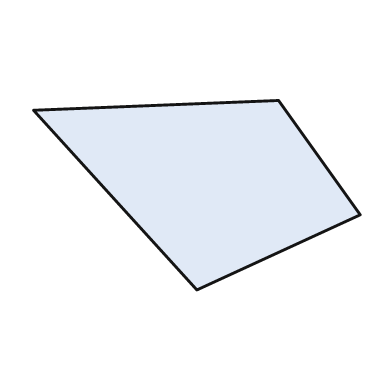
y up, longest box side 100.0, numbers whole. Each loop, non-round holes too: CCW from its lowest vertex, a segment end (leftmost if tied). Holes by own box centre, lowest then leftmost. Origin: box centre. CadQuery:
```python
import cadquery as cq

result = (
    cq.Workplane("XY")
    .moveTo(0.0, -29.0)
    .lineTo(50.0, -6.0)
    .lineTo(25.0, 29.0)
    .lineTo(-50.0, 26.0)
    .close()
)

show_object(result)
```